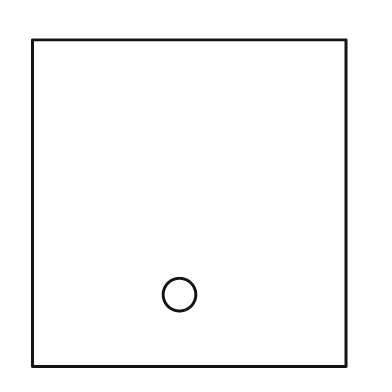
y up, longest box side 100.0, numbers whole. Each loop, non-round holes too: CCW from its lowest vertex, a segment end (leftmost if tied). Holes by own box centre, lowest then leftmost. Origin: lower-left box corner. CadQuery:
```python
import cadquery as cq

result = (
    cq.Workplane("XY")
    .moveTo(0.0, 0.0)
    .lineTo(96.0, 0.0)
    .lineTo(96.0, 100.0)
    .lineTo(0.0, 100.0)
    .close()
    .moveTo(45.0, 22.0)
    .circle(5.0)
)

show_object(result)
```